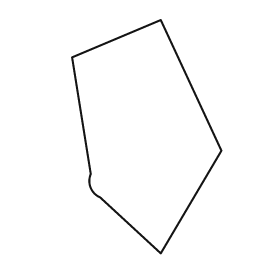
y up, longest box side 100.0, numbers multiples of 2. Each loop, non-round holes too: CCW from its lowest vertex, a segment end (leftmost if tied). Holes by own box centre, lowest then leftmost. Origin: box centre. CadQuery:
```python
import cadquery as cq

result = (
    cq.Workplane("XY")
    .moveTo(6.0, -50.0)
    .lineTo(32.0, -6.0)
    .lineTo(6.0, 50.0)
    .lineTo(-32.0, 34.0)
    .lineTo(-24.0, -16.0)
    .threePointArc((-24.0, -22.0), (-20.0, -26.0))
    .close()
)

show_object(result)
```